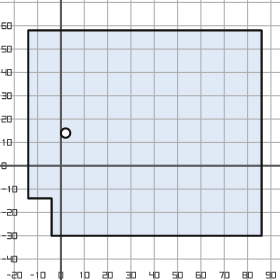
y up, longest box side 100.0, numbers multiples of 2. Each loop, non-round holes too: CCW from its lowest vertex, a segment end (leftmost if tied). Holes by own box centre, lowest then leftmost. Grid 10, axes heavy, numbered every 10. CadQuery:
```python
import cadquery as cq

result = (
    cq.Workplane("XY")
    .moveTo(-4.0, -30.0)
    .lineTo(86.0, -30.0)
    .lineTo(86.0, 58.0)
    .lineTo(-14.0, 58.0)
    .lineTo(-14.0, -14.0)
    .lineTo(-4.0, -14.0)
    .close()
    .moveTo(2.0, 14.0)
    .circle(2.0)
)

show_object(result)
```